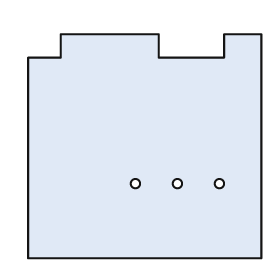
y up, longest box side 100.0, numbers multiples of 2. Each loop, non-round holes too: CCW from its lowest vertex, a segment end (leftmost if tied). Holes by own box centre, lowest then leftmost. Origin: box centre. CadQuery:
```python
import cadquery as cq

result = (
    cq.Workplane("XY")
    .moveTo(-50.0, -48.0)
    .lineTo(50.0, -48.0)
    .lineTo(50.0, 48.0)
    .lineTo(34.0, 48.0)
    .lineTo(34.0, 38.0)
    .lineTo(6.0, 38.0)
    .lineTo(6.0, 48.0)
    .lineTo(-36.0, 48.0)
    .lineTo(-36.0, 38.0)
    .lineTo(-50.0, 38.0)
    .close()
    .moveTo(-4.0, -16.0)
    .circle(2.0)
    .moveTo(14.0, -16.0)
    .circle(2.0)
    .moveTo(32.0, -16.0)
    .circle(2.0)
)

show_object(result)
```